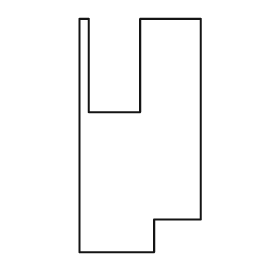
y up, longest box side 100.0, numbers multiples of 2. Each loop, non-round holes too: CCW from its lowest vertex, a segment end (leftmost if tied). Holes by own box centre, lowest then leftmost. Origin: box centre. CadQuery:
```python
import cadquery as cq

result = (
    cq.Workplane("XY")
    .moveTo(-26.0, -50.0)
    .lineTo(6.0, -50.0)
    .lineTo(6.0, -36.0)
    .lineTo(26.0, -36.0)
    .lineTo(26.0, 50.0)
    .lineTo(0.0, 50.0)
    .lineTo(0.0, 10.0)
    .lineTo(-22.0, 10.0)
    .lineTo(-22.0, 50.0)
    .lineTo(-26.0, 50.0)
    .close()
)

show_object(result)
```